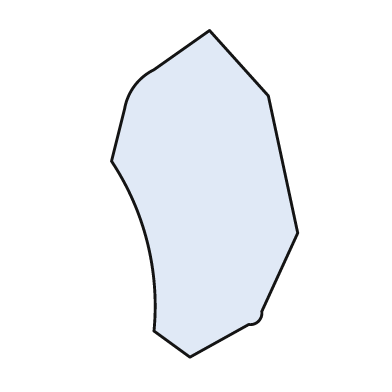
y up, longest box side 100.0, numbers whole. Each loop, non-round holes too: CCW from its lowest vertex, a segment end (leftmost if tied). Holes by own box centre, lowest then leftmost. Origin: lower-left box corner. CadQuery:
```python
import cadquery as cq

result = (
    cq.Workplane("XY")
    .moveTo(24.0, 0.0)
    .lineTo(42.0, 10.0)
    .threePointArc((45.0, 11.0), (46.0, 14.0))
    .lineTo(57.0, 38.0)
    .lineTo(48.0, 80.0)
    .lineTo(30.0, 100.0)
    .lineTo(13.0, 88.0)
    .threePointArc((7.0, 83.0), (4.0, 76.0))
    .lineTo(0.0, 60.0)
    .threePointArc((11.0, 35.0), (13.0, 8.0))
    .close()
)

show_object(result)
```